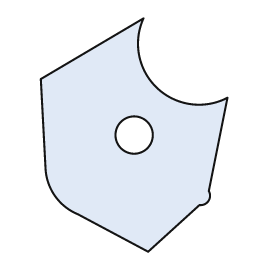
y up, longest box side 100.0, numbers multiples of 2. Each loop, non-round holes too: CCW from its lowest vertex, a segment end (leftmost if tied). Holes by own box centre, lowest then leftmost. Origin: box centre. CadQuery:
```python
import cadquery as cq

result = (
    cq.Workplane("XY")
    .moveTo(6.0, -50.0)
    .lineTo(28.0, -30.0)
    .threePointArc((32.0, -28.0), (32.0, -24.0))
    .lineTo(40.0, 16.0)
    .threePointArc((10.0, 20.0), (4.0, 50.0))
    .lineTo(-40.0, 24.0)
    .lineTo(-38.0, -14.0)
    .threePointArc((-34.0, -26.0), (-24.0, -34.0))
    .close()
    .moveTo(0.0, 0.0)
    .circle(8.0)
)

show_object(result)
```